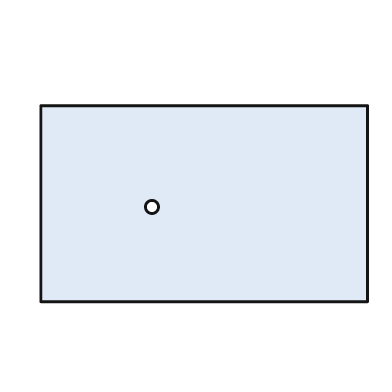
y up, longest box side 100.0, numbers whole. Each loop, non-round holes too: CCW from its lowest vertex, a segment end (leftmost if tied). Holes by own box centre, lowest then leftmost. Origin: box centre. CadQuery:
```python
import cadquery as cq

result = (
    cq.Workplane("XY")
    .moveTo(-50.0, -30.0)
    .lineTo(50.0, -30.0)
    .lineTo(50.0, 30.0)
    .lineTo(-50.0, 30.0)
    .close()
    .moveTo(-16.0, -1.0)
    .circle(2.0)
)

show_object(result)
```